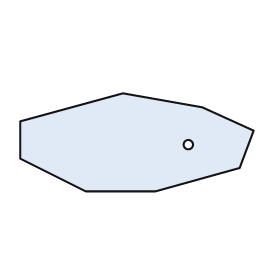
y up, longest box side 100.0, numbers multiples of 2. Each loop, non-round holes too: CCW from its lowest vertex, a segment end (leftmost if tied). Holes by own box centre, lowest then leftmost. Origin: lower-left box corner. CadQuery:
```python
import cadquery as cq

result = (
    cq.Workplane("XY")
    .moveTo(28.0, 0.0)
    .lineTo(58.0, 0.0)
    .lineTo(94.0, 10.0)
    .lineTo(100.0, 26.0)
    .lineTo(78.0, 36.0)
    .lineTo(44.0, 42.0)
    .lineTo(0.0, 30.0)
    .lineTo(0.0, 14.0)
    .close()
    .moveTo(72.0, 20.0)
    .circle(2.0)
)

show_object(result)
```